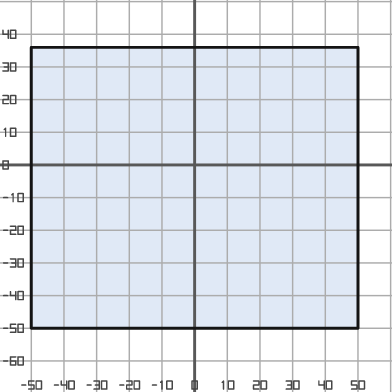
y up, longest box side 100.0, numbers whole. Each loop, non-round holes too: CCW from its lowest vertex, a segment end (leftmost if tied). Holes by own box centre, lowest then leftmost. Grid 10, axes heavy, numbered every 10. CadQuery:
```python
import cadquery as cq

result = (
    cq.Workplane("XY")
    .moveTo(-50.0, -50.0)
    .lineTo(50.0, -50.0)
    .lineTo(50.0, 36.0)
    .lineTo(-50.0, 36.0)
    .close()
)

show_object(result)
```